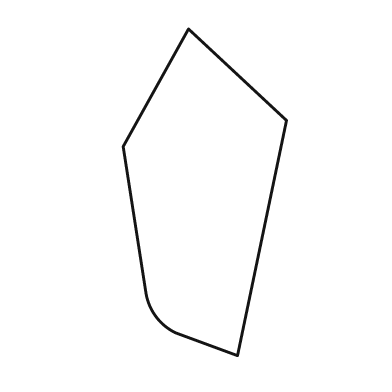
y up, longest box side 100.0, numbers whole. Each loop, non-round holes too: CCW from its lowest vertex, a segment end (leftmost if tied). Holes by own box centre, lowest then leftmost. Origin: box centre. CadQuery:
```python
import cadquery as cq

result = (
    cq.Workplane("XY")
    .moveTo(10.0, -50.0)
    .lineTo(25.0, 22.0)
    .lineTo(-5.0, 50.0)
    .lineTo(-25.0, 14.0)
    .lineTo(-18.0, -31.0)
    .threePointArc((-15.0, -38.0), (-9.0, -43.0))
    .close()
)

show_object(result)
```